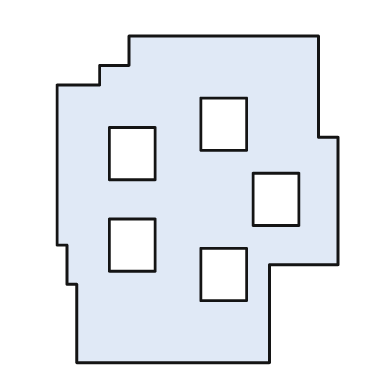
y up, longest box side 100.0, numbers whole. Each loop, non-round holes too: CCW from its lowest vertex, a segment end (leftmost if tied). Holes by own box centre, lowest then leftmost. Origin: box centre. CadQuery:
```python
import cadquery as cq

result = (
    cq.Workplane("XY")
    .moveTo(-37.0, -50.0)
    .lineTo(22.0, -50.0)
    .lineTo(22.0, -20.0)
    .lineTo(43.0, -20.0)
    .lineTo(43.0, 19.0)
    .lineTo(37.0, 19.0)
    .lineTo(37.0, 50.0)
    .lineTo(-21.0, 50.0)
    .lineTo(-21.0, 41.0)
    .lineTo(-30.0, 41.0)
    .lineTo(-30.0, 35.0)
    .lineTo(-43.0, 35.0)
    .lineTo(-43.0, -14.0)
    .lineTo(-40.0, -14.0)
    .lineTo(-40.0, -26.0)
    .lineTo(-37.0, -26.0)
    .close()
    .moveTo(1.0, -31.0)
    .lineTo(15.0, -31.0)
    .lineTo(15.0, -15.0)
    .lineTo(1.0, -15.0)
    .close()
    .moveTo(-27.0, -22.0)
    .lineTo(-13.0, -22.0)
    .lineTo(-13.0, -6.0)
    .lineTo(-27.0, -6.0)
    .close()
    .moveTo(17.0, -8.0)
    .lineTo(31.0, -8.0)
    .lineTo(31.0, 8.0)
    .lineTo(17.0, 8.0)
    .close()
    .moveTo(-27.0, 6.0)
    .lineTo(-13.0, 6.0)
    .lineTo(-13.0, 22.0)
    .lineTo(-27.0, 22.0)
    .close()
    .moveTo(1.0, 15.0)
    .lineTo(15.0, 15.0)
    .lineTo(15.0, 31.0)
    .lineTo(1.0, 31.0)
    .close()
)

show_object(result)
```